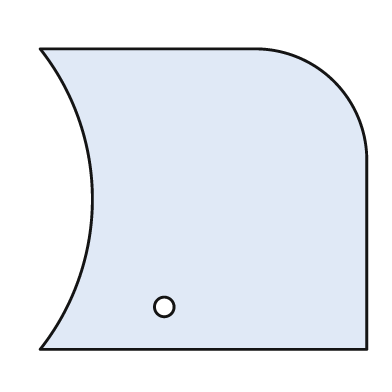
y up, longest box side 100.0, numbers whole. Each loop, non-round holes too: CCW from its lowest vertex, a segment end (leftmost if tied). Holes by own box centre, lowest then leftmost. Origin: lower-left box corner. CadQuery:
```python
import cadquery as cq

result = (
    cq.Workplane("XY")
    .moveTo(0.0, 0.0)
    .lineTo(100.0, 0.0)
    .lineTo(100.0, 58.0)
    .threePointArc((90.0, 82.0), (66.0, 92.0))
    .lineTo(0.0, 92.0)
    .threePointArc((16.0, 46.0), (0.0, 0.0))
    .close()
    .moveTo(38.0, 13.0)
    .circle(3.0)
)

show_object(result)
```